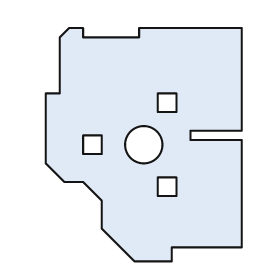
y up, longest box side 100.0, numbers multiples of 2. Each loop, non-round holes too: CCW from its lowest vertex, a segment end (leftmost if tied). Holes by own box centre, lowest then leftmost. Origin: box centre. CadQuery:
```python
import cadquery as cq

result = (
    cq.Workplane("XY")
    .moveTo(-4.0, -50.0)
    .lineTo(12.0, -50.0)
    .lineTo(12.0, -44.0)
    .lineTo(42.0, -44.0)
    .lineTo(42.0, 2.0)
    .lineTo(20.0, 2.0)
    .lineTo(20.0, 6.0)
    .lineTo(42.0, 6.0)
    .lineTo(42.0, 50.0)
    .lineTo(-2.0, 50.0)
    .lineTo(-2.0, 46.0)
    .lineTo(-26.0, 46.0)
    .lineTo(-26.0, 50.0)
    .lineTo(-32.0, 50.0)
    .lineTo(-36.0, 46.0)
    .lineTo(-36.0, 22.0)
    .lineTo(-42.0, 22.0)
    .lineTo(-42.0, -8.0)
    .lineTo(-34.0, -16.0)
    .lineTo(-26.0, -16.0)
    .lineTo(-18.0, -24.0)
    .lineTo(-18.0, -36.0)
    .close()
    .moveTo(6.0, -22.0)
    .lineTo(14.0, -22.0)
    .lineTo(14.0, -14.0)
    .lineTo(6.0, -14.0)
    .close()
    .moveTo(-26.0, -4.0)
    .lineTo(-18.0, -4.0)
    .lineTo(-18.0, 4.0)
    .lineTo(-26.0, 4.0)
    .close()
    .moveTo(0.0, 0.0)
    .circle(8.0)
    .moveTo(6.0, 14.0)
    .lineTo(14.0, 14.0)
    .lineTo(14.0, 22.0)
    .lineTo(6.0, 22.0)
    .close()
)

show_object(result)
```